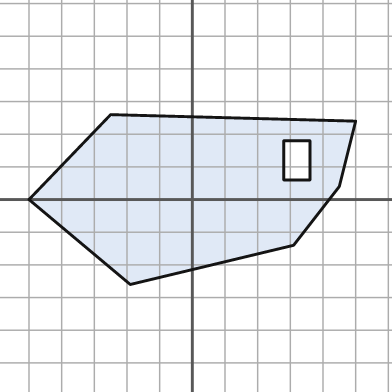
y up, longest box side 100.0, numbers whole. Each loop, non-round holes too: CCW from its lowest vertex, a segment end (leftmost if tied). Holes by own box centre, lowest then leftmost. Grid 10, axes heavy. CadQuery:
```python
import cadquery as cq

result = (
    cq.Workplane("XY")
    .moveTo(-19.0, -26.0)
    .lineTo(31.0, -14.0)
    .lineTo(45.0, 4.0)
    .lineTo(50.0, 24.0)
    .lineTo(-25.0, 26.0)
    .lineTo(-50.0, 0.0)
    .close()
    .moveTo(28.0, 6.0)
    .lineTo(36.0, 6.0)
    .lineTo(36.0, 18.0)
    .lineTo(28.0, 18.0)
    .close()
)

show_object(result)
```